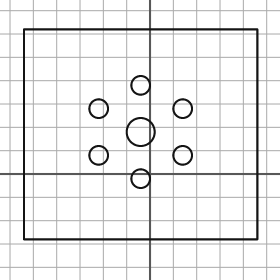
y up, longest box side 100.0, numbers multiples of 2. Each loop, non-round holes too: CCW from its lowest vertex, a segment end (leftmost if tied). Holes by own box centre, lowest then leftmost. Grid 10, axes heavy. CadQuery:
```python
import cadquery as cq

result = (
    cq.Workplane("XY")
    .moveTo(-54.0, -28.0)
    .lineTo(46.0, -28.0)
    .lineTo(46.0, 62.0)
    .lineTo(-54.0, 62.0)
    .close()
    .moveTo(-4.0, -2.0)
    .circle(4.0)
    .moveTo(-22.0, 8.0)
    .circle(4.0)
    .moveTo(14.0, 8.0)
    .circle(4.0)
    .moveTo(-4.0, 18.0)
    .circle(6.0)
    .moveTo(-22.0, 28.0)
    .circle(4.0)
    .moveTo(14.0, 28.0)
    .circle(4.0)
    .moveTo(-4.0, 38.0)
    .circle(4.0)
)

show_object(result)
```